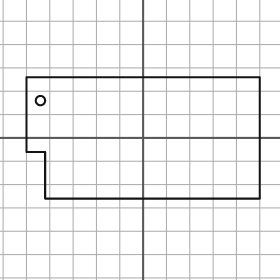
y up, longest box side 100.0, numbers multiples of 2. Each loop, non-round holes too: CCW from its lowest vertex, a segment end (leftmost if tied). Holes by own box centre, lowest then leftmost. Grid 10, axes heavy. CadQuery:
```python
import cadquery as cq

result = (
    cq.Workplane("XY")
    .moveTo(-42.0, -26.0)
    .lineTo(50.0, -26.0)
    .lineTo(50.0, 26.0)
    .lineTo(-50.0, 26.0)
    .lineTo(-50.0, -6.0)
    .lineTo(-42.0, -6.0)
    .close()
    .moveTo(-44.0, 16.0)
    .circle(2.0)
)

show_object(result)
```